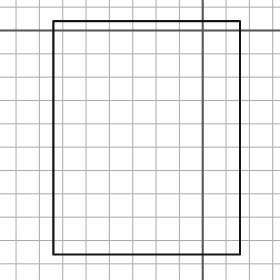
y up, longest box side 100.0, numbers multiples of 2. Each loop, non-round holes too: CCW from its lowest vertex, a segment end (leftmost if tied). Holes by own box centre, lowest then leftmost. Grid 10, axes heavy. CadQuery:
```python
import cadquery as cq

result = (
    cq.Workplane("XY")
    .moveTo(-64.0, -96.0)
    .lineTo(16.0, -96.0)
    .lineTo(16.0, 4.0)
    .lineTo(-64.0, 4.0)
    .close()
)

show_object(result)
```